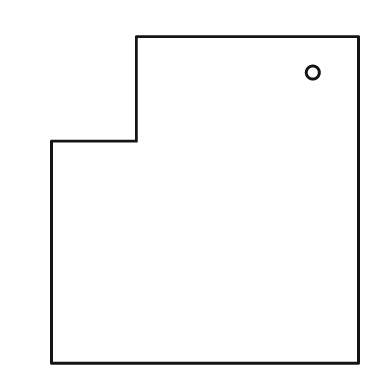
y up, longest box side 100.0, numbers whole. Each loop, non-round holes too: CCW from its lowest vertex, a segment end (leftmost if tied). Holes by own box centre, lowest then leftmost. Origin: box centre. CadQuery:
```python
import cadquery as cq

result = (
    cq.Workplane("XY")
    .moveTo(-47.0, -50.0)
    .lineTo(47.0, -50.0)
    .lineTo(47.0, 50.0)
    .lineTo(-21.0, 50.0)
    .lineTo(-21.0, 18.0)
    .lineTo(-47.0, 18.0)
    .close()
    .moveTo(33.0, 39.0)
    .circle(2.0)
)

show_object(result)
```